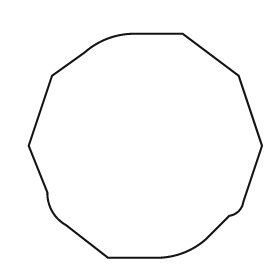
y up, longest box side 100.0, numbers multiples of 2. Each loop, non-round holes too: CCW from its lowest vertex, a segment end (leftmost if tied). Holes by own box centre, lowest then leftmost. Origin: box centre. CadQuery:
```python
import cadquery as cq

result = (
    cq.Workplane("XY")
    .moveTo(-16.0, -48.0)
    .lineTo(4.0, -48.0)
    .threePointArc((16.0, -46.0), (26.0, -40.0))
    .lineTo(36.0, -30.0)
    .threePointArc((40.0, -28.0), (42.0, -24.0))
    .lineTo(50.0, 0.0)
    .lineTo(40.0, 30.0)
    .lineTo(16.0, 48.0)
    .lineTo(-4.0, 48.0)
    .threePointArc((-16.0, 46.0), (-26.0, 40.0))
    .lineTo(-40.0, 30.0)
    .lineTo(-50.0, 0.0)
    .lineTo(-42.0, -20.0)
    .threePointArc((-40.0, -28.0), (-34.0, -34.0))
    .close()
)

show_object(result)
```